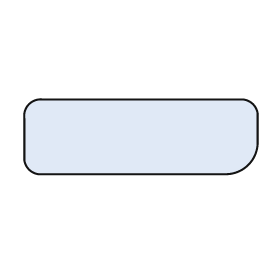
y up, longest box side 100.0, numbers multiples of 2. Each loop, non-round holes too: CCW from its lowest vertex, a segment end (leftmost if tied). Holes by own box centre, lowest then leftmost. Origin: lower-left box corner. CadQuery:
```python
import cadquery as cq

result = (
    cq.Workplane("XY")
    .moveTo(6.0, 0.0)
    .lineTo(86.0, 0.0)
    .threePointArc((96.0, 4.0), (100.0, 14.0))
    .lineTo(100.0, 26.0)
    .threePointArc((98.0, 30.0), (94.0, 32.0))
    .lineTo(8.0, 32.0)
    .threePointArc((2.0, 30.0), (0.0, 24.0))
    .lineTo(0.0, 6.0)
    .threePointArc((2.0, 2.0), (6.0, 0.0))
    .close()
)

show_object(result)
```